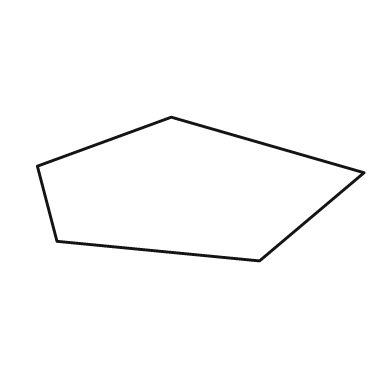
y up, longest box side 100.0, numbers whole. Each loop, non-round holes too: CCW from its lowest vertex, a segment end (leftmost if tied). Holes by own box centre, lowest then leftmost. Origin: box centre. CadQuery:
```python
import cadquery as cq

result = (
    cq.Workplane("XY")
    .moveTo(18.0, -22.0)
    .lineTo(50.0, 5.0)
    .lineTo(-9.0, 22.0)
    .lineTo(-50.0, 7.0)
    .lineTo(-44.0, -16.0)
    .close()
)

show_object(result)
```